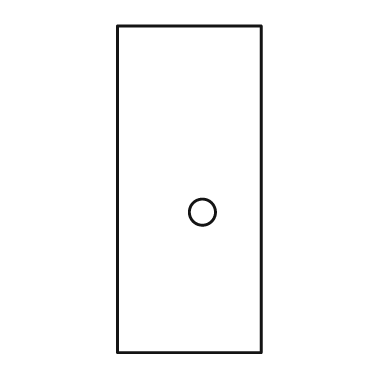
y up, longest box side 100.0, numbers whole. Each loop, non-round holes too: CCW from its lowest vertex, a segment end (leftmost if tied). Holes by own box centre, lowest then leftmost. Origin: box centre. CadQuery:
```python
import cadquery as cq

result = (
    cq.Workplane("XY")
    .moveTo(-22.0, -50.0)
    .lineTo(22.0, -50.0)
    .lineTo(22.0, 50.0)
    .lineTo(-22.0, 50.0)
    .close()
    .moveTo(4.0, -7.0)
    .circle(4.0)
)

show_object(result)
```